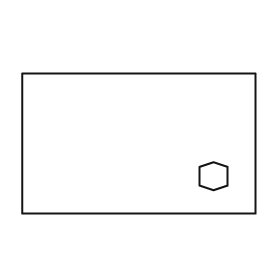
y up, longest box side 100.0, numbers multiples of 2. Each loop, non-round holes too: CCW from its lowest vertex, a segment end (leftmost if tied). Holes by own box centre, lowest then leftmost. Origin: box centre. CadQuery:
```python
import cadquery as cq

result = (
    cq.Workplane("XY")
    .moveTo(-50.0, -30.0)
    .lineTo(50.0, -30.0)
    .lineTo(50.0, 30.0)
    .lineTo(-50.0, 30.0)
    .close()
    .moveTo(32.0, -20.0)
    .lineTo(38.0, -18.0)
    .lineTo(38.0, -10.0)
    .lineTo(32.0, -8.0)
    .lineTo(26.0, -10.0)
    .lineTo(26.0, -18.0)
    .close()
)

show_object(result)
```